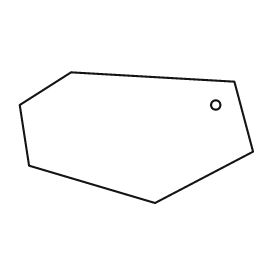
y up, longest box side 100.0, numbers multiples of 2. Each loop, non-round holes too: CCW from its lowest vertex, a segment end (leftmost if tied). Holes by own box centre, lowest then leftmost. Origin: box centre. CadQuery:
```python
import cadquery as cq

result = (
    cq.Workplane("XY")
    .moveTo(8.0, -28.0)
    .lineTo(50.0, -6.0)
    .lineTo(42.0, 24.0)
    .lineTo(-28.0, 28.0)
    .lineTo(-50.0, 14.0)
    .lineTo(-46.0, -12.0)
    .close()
    .moveTo(34.0, 14.0)
    .circle(2.0)
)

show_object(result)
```